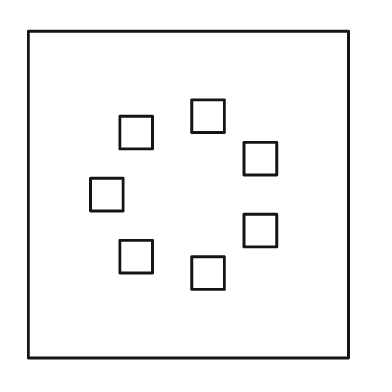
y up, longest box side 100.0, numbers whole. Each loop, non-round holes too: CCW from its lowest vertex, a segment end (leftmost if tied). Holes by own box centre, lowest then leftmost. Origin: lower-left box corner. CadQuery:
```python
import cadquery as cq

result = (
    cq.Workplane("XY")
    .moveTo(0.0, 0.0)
    .lineTo(98.0, 0.0)
    .lineTo(98.0, 100.0)
    .lineTo(0.0, 100.0)
    .close()
    .moveTo(50.0, 21.0)
    .lineTo(60.0, 21.0)
    .lineTo(60.0, 31.0)
    .lineTo(50.0, 31.0)
    .close()
    .moveTo(28.0, 26.0)
    .lineTo(38.0, 26.0)
    .lineTo(38.0, 36.0)
    .lineTo(28.0, 36.0)
    .close()
    .moveTo(66.0, 34.0)
    .lineTo(76.0, 34.0)
    .lineTo(76.0, 44.0)
    .lineTo(66.0, 44.0)
    .close()
    .moveTo(19.0, 45.0)
    .lineTo(29.0, 45.0)
    .lineTo(29.0, 55.0)
    .lineTo(19.0, 55.0)
    .close()
    .moveTo(66.0, 56.0)
    .lineTo(76.0, 56.0)
    .lineTo(76.0, 66.0)
    .lineTo(66.0, 66.0)
    .close()
    .moveTo(28.0, 64.0)
    .lineTo(38.0, 64.0)
    .lineTo(38.0, 74.0)
    .lineTo(28.0, 74.0)
    .close()
    .moveTo(50.0, 69.0)
    .lineTo(60.0, 69.0)
    .lineTo(60.0, 79.0)
    .lineTo(50.0, 79.0)
    .close()
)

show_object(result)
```